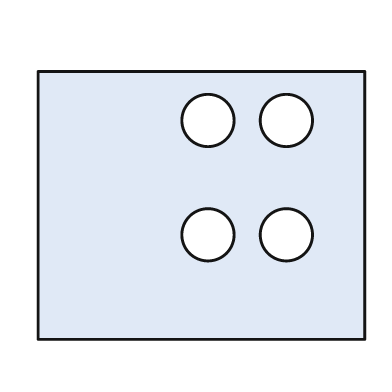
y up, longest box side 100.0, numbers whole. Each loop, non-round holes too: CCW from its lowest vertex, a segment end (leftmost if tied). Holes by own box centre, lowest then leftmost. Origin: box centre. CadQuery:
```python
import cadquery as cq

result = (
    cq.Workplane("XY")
    .moveTo(-50.0, -41.0)
    .lineTo(50.0, -41.0)
    .lineTo(50.0, 41.0)
    .lineTo(-50.0, 41.0)
    .close()
    .moveTo(2.0, -9.0)
    .circle(8.0)
    .moveTo(26.0, -9.0)
    .circle(8.0)
    .moveTo(2.0, 26.0)
    .circle(8.0)
    .moveTo(26.0, 26.0)
    .circle(8.0)
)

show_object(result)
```